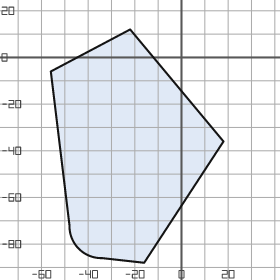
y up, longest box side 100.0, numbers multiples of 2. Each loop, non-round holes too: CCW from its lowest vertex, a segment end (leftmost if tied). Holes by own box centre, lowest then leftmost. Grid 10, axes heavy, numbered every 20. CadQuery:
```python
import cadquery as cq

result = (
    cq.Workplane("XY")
    .moveTo(-16.0, -88.0)
    .lineTo(18.0, -36.0)
    .lineTo(-22.0, 12.0)
    .lineTo(-56.0, -6.0)
    .lineTo(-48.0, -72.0)
    .threePointArc((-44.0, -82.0), (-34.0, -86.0))
    .close()
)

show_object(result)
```